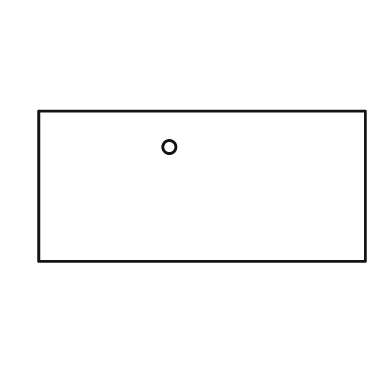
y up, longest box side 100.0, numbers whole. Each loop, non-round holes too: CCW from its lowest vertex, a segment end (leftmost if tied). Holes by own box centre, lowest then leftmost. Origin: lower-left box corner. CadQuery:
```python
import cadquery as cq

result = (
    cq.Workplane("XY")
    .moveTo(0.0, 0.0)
    .lineTo(100.0, 0.0)
    .lineTo(100.0, 46.0)
    .lineTo(0.0, 46.0)
    .close()
    .moveTo(40.0, 35.0)
    .circle(2.0)
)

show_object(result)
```